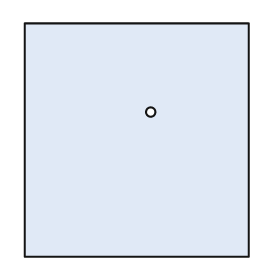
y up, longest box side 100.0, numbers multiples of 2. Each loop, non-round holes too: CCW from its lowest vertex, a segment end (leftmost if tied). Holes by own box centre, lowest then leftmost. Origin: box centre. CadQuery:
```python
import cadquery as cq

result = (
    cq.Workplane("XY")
    .moveTo(-48.0, -50.0)
    .lineTo(48.0, -50.0)
    .lineTo(48.0, 50.0)
    .lineTo(-48.0, 50.0)
    .close()
    .moveTo(6.0, 12.0)
    .circle(2.0)
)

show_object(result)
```